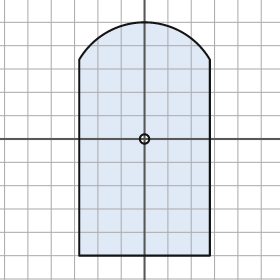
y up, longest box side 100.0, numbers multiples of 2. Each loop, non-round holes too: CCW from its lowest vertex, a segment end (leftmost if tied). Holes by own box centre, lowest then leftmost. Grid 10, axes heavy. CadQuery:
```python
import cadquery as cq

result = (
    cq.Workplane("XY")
    .moveTo(-28.0, -50.0)
    .lineTo(28.0, -50.0)
    .lineTo(28.0, 34.0)
    .threePointArc((0.0, 50.0), (-28.0, 34.0))
    .close()
    .moveTo(0.0, 0.0)
    .circle(2.0)
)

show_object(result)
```